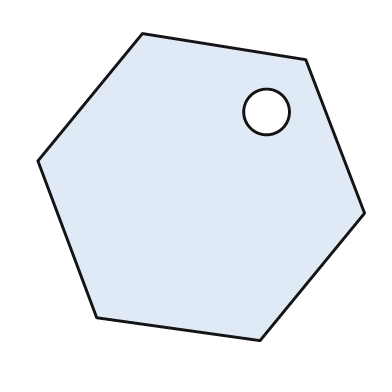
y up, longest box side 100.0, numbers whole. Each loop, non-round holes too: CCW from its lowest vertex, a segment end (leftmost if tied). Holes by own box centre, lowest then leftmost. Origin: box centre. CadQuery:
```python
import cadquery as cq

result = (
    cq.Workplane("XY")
    .moveTo(18.0, -47.0)
    .lineTo(50.0, -8.0)
    .lineTo(32.0, 39.0)
    .lineTo(-18.0, 47.0)
    .lineTo(-50.0, 8.0)
    .lineTo(-32.0, -40.0)
    .close()
    .moveTo(20.0, 23.0)
    .circle(7.0)
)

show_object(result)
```